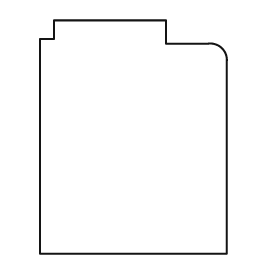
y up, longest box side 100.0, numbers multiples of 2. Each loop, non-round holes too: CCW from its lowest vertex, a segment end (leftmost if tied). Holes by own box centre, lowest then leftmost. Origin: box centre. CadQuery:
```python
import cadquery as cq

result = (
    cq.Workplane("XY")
    .moveTo(-40.0, -50.0)
    .lineTo(40.0, -50.0)
    .lineTo(40.0, 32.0)
    .threePointArc((38.0, 38.0), (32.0, 40.0))
    .lineTo(14.0, 40.0)
    .lineTo(14.0, 50.0)
    .lineTo(-34.0, 50.0)
    .lineTo(-34.0, 42.0)
    .lineTo(-40.0, 42.0)
    .close()
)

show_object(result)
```